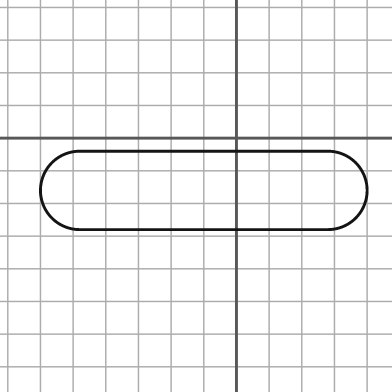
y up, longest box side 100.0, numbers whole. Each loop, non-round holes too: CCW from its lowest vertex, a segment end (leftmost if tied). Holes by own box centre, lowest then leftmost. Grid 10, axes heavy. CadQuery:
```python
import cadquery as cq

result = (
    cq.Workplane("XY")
    .moveTo(-48.0, -28.0)
    .lineTo(28.0, -28.0)
    .threePointArc((40.0, -16.0), (28.0, -4.0))
    .lineTo(-48.0, -4.0)
    .threePointArc((-60.0, -16.0), (-48.0, -28.0))
    .close()
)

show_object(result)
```